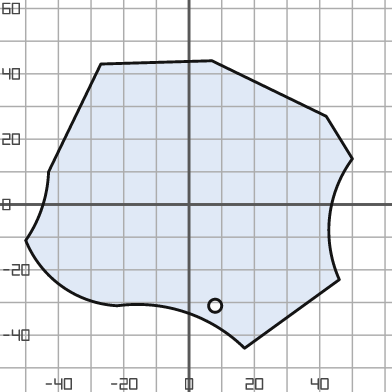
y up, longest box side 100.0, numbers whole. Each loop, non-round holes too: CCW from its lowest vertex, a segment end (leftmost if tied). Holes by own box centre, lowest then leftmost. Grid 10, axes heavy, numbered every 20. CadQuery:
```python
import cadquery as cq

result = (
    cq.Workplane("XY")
    .moveTo(17.0, -44.0)
    .lineTo(46.0, -23.0)
    .threePointArc((43.0, -4.0), (50.0, 14.0))
    .lineTo(42.0, 27.0)
    .lineTo(7.0, 44.0)
    .lineTo(-27.0, 43.0)
    .lineTo(-43.0, 10.0)
    .threePointArc((-45.0, -1.0), (-50.0, -11.0))
    .threePointArc((-39.0, -25.0), (-22.0, -31.0))
    .threePointArc((-1.0, -33.0), (17.0, -44.0))
    .close()
    .moveTo(8.0, -31.0)
    .circle(2.0)
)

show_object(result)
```